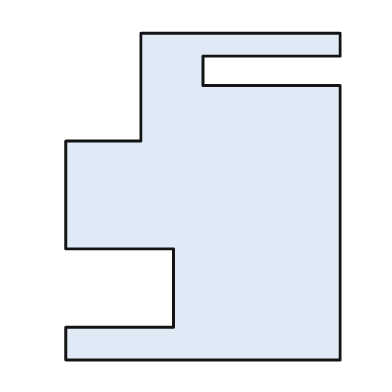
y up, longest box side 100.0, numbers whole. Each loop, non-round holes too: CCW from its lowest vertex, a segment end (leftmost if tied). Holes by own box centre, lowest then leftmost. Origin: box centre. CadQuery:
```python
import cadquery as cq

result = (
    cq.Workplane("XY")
    .moveTo(-42.0, -50.0)
    .lineTo(42.0, -50.0)
    .lineTo(42.0, 34.0)
    .lineTo(0.0, 34.0)
    .lineTo(0.0, 43.0)
    .lineTo(42.0, 43.0)
    .lineTo(42.0, 50.0)
    .lineTo(-19.0, 50.0)
    .lineTo(-19.0, 17.0)
    .lineTo(-42.0, 17.0)
    .lineTo(-42.0, -16.0)
    .lineTo(-9.0, -16.0)
    .lineTo(-9.0, -40.0)
    .lineTo(-42.0, -40.0)
    .close()
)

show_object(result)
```